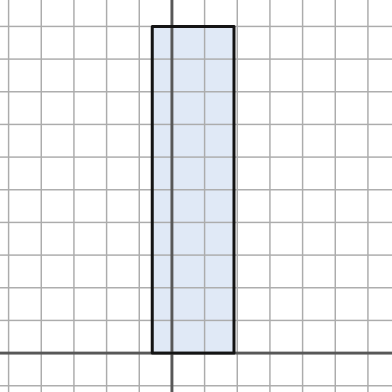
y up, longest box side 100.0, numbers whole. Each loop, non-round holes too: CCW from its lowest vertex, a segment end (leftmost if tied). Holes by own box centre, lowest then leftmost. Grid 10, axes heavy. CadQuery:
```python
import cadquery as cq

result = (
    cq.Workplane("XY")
    .moveTo(-6.0, 0.0)
    .lineTo(19.0, 0.0)
    .lineTo(19.0, 100.0)
    .lineTo(-6.0, 100.0)
    .close()
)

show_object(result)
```